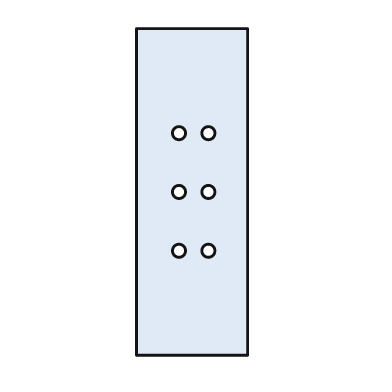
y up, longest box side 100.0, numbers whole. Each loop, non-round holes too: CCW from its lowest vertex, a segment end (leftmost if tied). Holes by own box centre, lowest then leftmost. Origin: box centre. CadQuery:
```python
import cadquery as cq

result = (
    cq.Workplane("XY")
    .moveTo(-17.0, -50.0)
    .lineTo(17.0, -50.0)
    .lineTo(17.0, 50.0)
    .lineTo(-17.0, 50.0)
    .close()
    .moveTo(-4.0, -18.0)
    .circle(2.0)
    .moveTo(5.0, -18.0)
    .circle(2.0)
    .moveTo(-4.0, 0.0)
    .circle(2.0)
    .moveTo(5.0, 0.0)
    .circle(2.0)
    .moveTo(-4.0, 18.0)
    .circle(2.0)
    .moveTo(5.0, 18.0)
    .circle(2.0)
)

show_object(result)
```